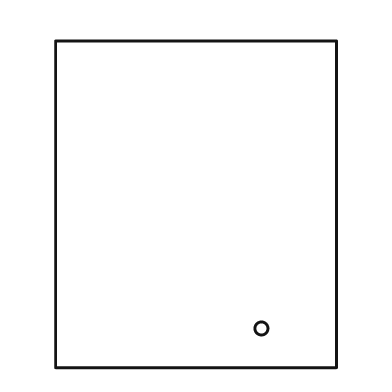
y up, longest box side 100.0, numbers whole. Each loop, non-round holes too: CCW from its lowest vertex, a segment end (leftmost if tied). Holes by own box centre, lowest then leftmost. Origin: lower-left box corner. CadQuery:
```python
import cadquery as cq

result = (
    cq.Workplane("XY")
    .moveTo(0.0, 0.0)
    .lineTo(86.0, 0.0)
    .lineTo(86.0, 100.0)
    .lineTo(0.0, 100.0)
    .close()
    .moveTo(63.0, 12.0)
    .circle(2.0)
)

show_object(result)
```